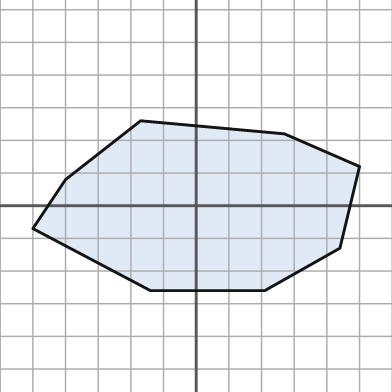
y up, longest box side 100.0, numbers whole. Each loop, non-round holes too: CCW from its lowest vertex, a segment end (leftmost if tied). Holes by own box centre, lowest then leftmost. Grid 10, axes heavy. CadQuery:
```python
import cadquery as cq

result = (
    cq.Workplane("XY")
    .moveTo(-14.0, -26.0)
    .lineTo(21.0, -26.0)
    .lineTo(44.0, -13.0)
    .lineTo(50.0, 12.0)
    .lineTo(27.0, 22.0)
    .lineTo(-17.0, 26.0)
    .lineTo(-40.0, 8.0)
    .lineTo(-50.0, -7.0)
    .close()
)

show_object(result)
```